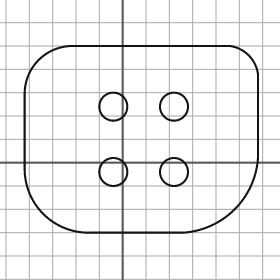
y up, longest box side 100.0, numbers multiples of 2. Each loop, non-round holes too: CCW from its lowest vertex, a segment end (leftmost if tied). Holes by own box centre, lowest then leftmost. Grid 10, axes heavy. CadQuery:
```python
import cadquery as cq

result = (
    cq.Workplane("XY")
    .moveTo(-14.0, -30.0)
    .lineTo(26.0, -30.0)
    .threePointArc((48.0, -20.0), (58.0, 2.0))
    .lineTo(58.0, 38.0)
    .threePointArc((54.0, 46.0), (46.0, 50.0))
    .lineTo(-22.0, 50.0)
    .threePointArc((-36.0, 44.0), (-42.0, 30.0))
    .lineTo(-42.0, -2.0)
    .threePointArc((-34.0, -22.0), (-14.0, -30.0))
    .close()
    .moveTo(-4.0, -4.0)
    .circle(6.0)
    .moveTo(22.0, -4.0)
    .circle(6.0)
    .moveTo(-4.0, 24.0)
    .circle(6.0)
    .moveTo(22.0, 24.0)
    .circle(6.0)
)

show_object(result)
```